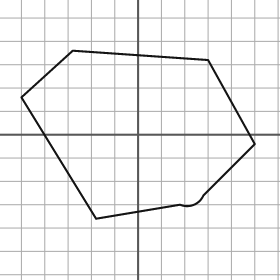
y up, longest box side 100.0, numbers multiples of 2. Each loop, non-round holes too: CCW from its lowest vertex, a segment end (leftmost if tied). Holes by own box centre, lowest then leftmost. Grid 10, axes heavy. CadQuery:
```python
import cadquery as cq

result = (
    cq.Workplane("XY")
    .moveTo(-18.0, -36.0)
    .lineTo(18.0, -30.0)
    .threePointArc((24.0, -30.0), (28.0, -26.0))
    .lineTo(50.0, -4.0)
    .lineTo(30.0, 32.0)
    .lineTo(-28.0, 36.0)
    .lineTo(-50.0, 16.0)
    .close()
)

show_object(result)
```